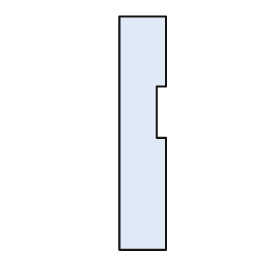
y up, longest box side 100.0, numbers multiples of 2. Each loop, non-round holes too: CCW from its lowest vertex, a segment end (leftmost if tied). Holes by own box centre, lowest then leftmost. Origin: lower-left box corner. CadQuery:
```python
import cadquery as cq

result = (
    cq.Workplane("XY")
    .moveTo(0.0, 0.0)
    .lineTo(20.0, 0.0)
    .lineTo(20.0, 48.0)
    .lineTo(16.0, 48.0)
    .lineTo(16.0, 70.0)
    .lineTo(20.0, 70.0)
    .lineTo(20.0, 100.0)
    .lineTo(0.0, 100.0)
    .close()
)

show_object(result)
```